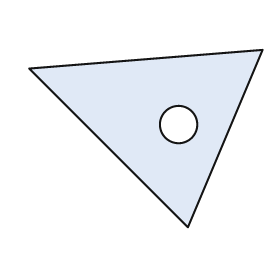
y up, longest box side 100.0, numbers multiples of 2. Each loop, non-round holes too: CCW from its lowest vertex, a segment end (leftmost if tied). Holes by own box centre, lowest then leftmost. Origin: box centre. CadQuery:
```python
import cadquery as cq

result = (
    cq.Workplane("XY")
    .moveTo(18.0, -38.0)
    .lineTo(50.0, 38.0)
    .lineTo(-50.0, 30.0)
    .close()
    .moveTo(14.0, 6.0)
    .circle(8.0)
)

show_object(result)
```